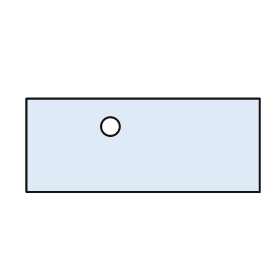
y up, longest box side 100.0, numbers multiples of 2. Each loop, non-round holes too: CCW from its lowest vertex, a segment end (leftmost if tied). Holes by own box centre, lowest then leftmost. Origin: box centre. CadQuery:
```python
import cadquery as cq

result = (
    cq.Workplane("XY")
    .moveTo(-50.0, -20.0)
    .lineTo(50.0, -20.0)
    .lineTo(50.0, 20.0)
    .lineTo(-50.0, 20.0)
    .close()
    .moveTo(-14.0, 8.0)
    .circle(4.0)
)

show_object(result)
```